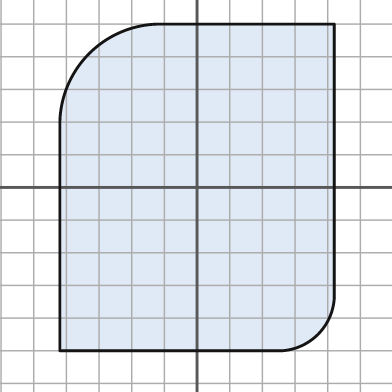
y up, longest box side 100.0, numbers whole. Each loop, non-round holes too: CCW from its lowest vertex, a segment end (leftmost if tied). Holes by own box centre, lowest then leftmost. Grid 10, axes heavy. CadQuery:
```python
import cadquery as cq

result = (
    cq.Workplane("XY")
    .moveTo(-42.0, -50.0)
    .lineTo(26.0, -50.0)
    .threePointArc((37.0, -45.0), (42.0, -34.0))
    .lineTo(42.0, 50.0)
    .lineTo(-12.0, 50.0)
    .threePointArc((-33.0, 41.0), (-42.0, 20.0))
    .close()
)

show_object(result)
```